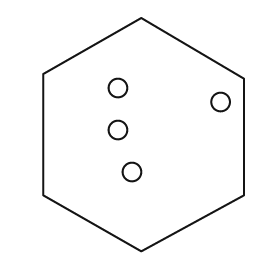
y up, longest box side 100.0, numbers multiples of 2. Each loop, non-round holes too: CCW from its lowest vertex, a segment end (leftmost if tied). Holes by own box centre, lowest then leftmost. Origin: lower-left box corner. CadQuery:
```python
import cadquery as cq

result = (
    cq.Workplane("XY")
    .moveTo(42.0, 0.0)
    .lineTo(86.0, 24.0)
    .lineTo(86.0, 74.0)
    .lineTo(42.0, 100.0)
    .lineTo(0.0, 76.0)
    .lineTo(0.0, 24.0)
    .close()
    .moveTo(38.0, 34.0)
    .circle(4.0)
    .moveTo(32.0, 52.0)
    .circle(4.0)
    .moveTo(76.0, 64.0)
    .circle(4.0)
    .moveTo(32.0, 70.0)
    .circle(4.0)
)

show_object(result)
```